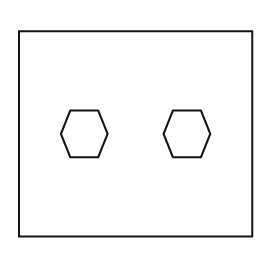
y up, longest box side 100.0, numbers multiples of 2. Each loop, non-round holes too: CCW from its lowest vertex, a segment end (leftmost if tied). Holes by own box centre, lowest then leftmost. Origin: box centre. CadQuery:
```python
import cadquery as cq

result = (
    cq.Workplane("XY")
    .moveTo(-50.0, -44.0)
    .lineTo(50.0, -44.0)
    .lineTo(50.0, 44.0)
    .lineTo(-50.0, 44.0)
    .close()
    .moveTo(-28.0, -10.0)
    .lineTo(-16.0, -10.0)
    .lineTo(-12.0, 0.0)
    .lineTo(-16.0, 10.0)
    .lineTo(-28.0, 10.0)
    .lineTo(-32.0, 0.0)
    .close()
    .moveTo(16.0, -10.0)
    .lineTo(28.0, -10.0)
    .lineTo(32.0, 0.0)
    .lineTo(28.0, 10.0)
    .lineTo(16.0, 10.0)
    .lineTo(12.0, 0.0)
    .close()
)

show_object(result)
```